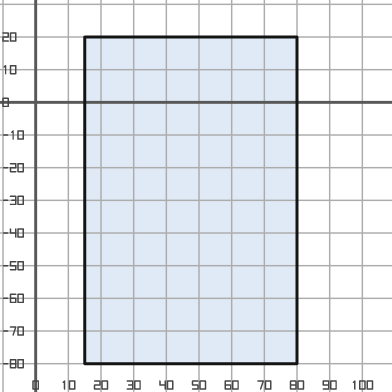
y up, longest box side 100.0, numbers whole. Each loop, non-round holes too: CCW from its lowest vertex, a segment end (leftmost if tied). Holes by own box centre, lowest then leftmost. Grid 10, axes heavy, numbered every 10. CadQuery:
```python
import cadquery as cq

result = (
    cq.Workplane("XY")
    .moveTo(15.0, -80.0)
    .lineTo(80.0, -80.0)
    .lineTo(80.0, 20.0)
    .lineTo(15.0, 20.0)
    .close()
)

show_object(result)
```